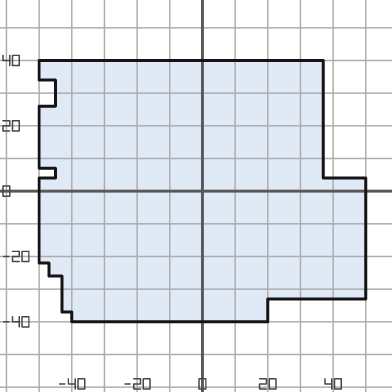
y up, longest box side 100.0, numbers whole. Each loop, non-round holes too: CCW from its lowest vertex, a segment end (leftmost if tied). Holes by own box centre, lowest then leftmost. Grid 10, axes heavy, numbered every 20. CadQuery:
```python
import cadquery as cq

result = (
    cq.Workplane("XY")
    .moveTo(-40.0, -40.0)
    .lineTo(20.0, -40.0)
    .lineTo(20.0, -33.0)
    .lineTo(50.0, -33.0)
    .lineTo(50.0, 4.0)
    .lineTo(37.0, 4.0)
    .lineTo(37.0, 40.0)
    .lineTo(-50.0, 40.0)
    .lineTo(-50.0, 34.0)
    .lineTo(-45.0, 34.0)
    .lineTo(-45.0, 26.0)
    .lineTo(-50.0, 26.0)
    .lineTo(-50.0, 7.0)
    .lineTo(-45.0, 7.0)
    .lineTo(-45.0, 4.0)
    .lineTo(-50.0, 4.0)
    .lineTo(-50.0, -22.0)
    .lineTo(-47.0, -22.0)
    .lineTo(-47.0, -26.0)
    .lineTo(-43.0, -26.0)
    .lineTo(-43.0, -37.0)
    .lineTo(-40.0, -37.0)
    .close()
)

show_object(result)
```